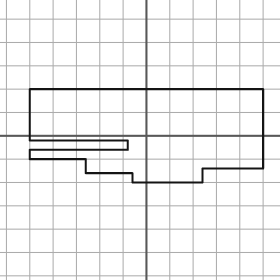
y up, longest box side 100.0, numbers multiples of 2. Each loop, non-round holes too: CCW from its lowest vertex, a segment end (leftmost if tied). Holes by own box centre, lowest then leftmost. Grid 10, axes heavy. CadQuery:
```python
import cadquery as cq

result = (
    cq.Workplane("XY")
    .moveTo(-6.0, -20.0)
    .lineTo(24.0, -20.0)
    .lineTo(24.0, -14.0)
    .lineTo(50.0, -14.0)
    .lineTo(50.0, 20.0)
    .lineTo(-50.0, 20.0)
    .lineTo(-50.0, -2.0)
    .lineTo(-8.0, -2.0)
    .lineTo(-8.0, -6.0)
    .lineTo(-50.0, -6.0)
    .lineTo(-50.0, -10.0)
    .lineTo(-26.0, -10.0)
    .lineTo(-26.0, -16.0)
    .lineTo(-6.0, -16.0)
    .close()
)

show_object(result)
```